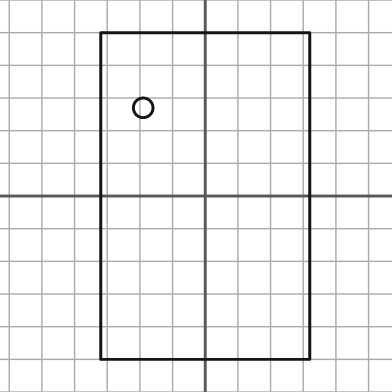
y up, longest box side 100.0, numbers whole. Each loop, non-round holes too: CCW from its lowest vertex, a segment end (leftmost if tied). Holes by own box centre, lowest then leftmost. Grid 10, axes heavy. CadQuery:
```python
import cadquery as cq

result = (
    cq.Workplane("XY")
    .moveTo(-32.0, -50.0)
    .lineTo(32.0, -50.0)
    .lineTo(32.0, 50.0)
    .lineTo(-32.0, 50.0)
    .close()
    .moveTo(-19.0, 27.0)
    .circle(3.0)
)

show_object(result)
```